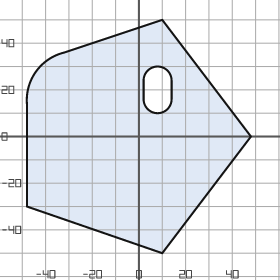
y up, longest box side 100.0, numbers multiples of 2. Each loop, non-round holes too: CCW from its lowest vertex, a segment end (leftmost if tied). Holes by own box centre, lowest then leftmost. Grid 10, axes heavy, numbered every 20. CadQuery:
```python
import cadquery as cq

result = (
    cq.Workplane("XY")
    .moveTo(10.0, -50.0)
    .lineTo(48.0, 0.0)
    .lineTo(10.0, 50.0)
    .lineTo(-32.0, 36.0)
    .threePointArc((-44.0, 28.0), (-48.0, 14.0))
    .lineTo(-48.0, -30.0)
    .close()
    .moveTo(2.0, 16.0)
    .threePointArc((8.0, 10.0), (14.0, 16.0))
    .lineTo(14.0, 24.0)
    .threePointArc((8.0, 30.0), (2.0, 24.0))
    .close()
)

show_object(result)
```